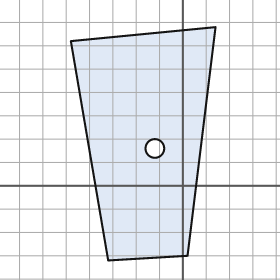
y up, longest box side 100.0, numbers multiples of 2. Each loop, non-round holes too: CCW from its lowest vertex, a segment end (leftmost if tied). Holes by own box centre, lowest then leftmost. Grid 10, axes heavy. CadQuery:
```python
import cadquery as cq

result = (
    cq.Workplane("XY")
    .moveTo(-32.0, -32.0)
    .lineTo(2.0, -30.0)
    .lineTo(14.0, 68.0)
    .lineTo(-48.0, 62.0)
    .close()
    .moveTo(-12.0, 16.0)
    .circle(4.0)
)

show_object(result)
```